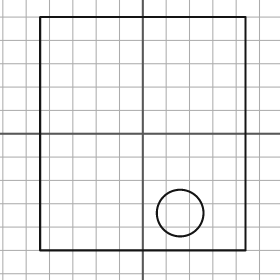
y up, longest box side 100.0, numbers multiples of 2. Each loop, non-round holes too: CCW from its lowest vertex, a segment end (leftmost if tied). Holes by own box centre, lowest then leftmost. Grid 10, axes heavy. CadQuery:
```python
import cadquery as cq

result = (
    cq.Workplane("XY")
    .moveTo(-44.0, -50.0)
    .lineTo(44.0, -50.0)
    .lineTo(44.0, 50.0)
    .lineTo(-44.0, 50.0)
    .close()
    .moveTo(16.0, -34.0)
    .circle(10.0)
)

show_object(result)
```